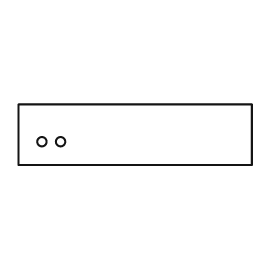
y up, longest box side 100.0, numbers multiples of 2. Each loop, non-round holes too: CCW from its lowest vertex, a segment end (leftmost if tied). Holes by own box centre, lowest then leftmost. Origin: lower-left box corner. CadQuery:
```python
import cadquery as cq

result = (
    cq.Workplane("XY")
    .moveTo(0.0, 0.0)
    .lineTo(100.0, 0.0)
    .lineTo(100.0, 26.0)
    .lineTo(0.0, 26.0)
    .close()
    .moveTo(10.0, 10.0)
    .circle(2.0)
    .moveTo(18.0, 10.0)
    .circle(2.0)
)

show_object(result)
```